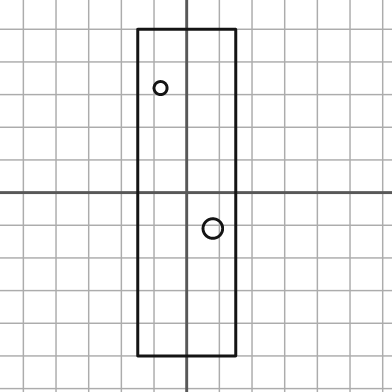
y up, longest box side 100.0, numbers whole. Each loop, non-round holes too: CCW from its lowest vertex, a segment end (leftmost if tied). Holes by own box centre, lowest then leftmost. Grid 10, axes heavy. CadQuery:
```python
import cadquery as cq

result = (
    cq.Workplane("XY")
    .moveTo(-15.0, -50.0)
    .lineTo(15.0, -50.0)
    .lineTo(15.0, 50.0)
    .lineTo(-15.0, 50.0)
    .close()
    .moveTo(8.0, -11.0)
    .circle(3.0)
    .moveTo(-8.0, 32.0)
    .circle(2.0)
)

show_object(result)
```